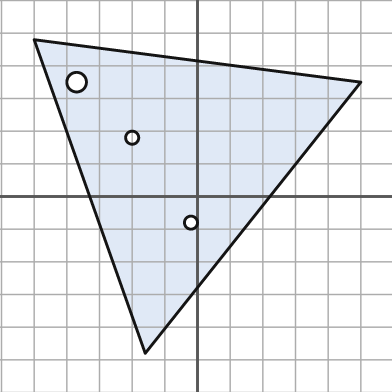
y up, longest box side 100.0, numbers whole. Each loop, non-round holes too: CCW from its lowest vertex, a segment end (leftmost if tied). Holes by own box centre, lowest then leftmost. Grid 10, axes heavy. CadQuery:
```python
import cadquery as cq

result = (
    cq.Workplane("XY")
    .moveTo(-16.0, -48.0)
    .lineTo(50.0, 35.0)
    .lineTo(-50.0, 48.0)
    .close()
    .moveTo(-2.0, -8.0)
    .circle(2.0)
    .moveTo(-20.0, 18.0)
    .circle(2.0)
    .moveTo(-37.0, 35.0)
    .circle(3.0)
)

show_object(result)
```